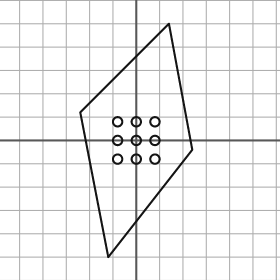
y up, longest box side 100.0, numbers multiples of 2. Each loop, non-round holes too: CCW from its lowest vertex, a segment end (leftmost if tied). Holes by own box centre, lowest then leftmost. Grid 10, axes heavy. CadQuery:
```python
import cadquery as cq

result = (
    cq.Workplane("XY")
    .moveTo(-12.0, -50.0)
    .lineTo(24.0, -4.0)
    .lineTo(14.0, 50.0)
    .lineTo(-24.0, 12.0)
    .close()
    .moveTo(-8.0, -8.0)
    .circle(2.0)
    .moveTo(0.0, -8.0)
    .circle(2.0)
    .moveTo(8.0, -8.0)
    .circle(2.0)
    .moveTo(-8.0, 0.0)
    .circle(2.0)
    .moveTo(0.0, 0.0)
    .circle(2.0)
    .moveTo(8.0, 0.0)
    .circle(2.0)
    .moveTo(-8.0, 8.0)
    .circle(2.0)
    .moveTo(0.0, 8.0)
    .circle(2.0)
    .moveTo(8.0, 8.0)
    .circle(2.0)
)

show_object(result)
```